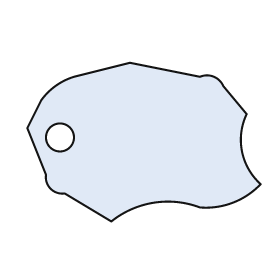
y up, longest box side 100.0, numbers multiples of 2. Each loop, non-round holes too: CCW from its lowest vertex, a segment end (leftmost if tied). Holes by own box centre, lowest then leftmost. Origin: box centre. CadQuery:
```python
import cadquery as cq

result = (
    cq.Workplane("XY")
    .moveTo(-14.0, -34.0)
    .threePointArc((4.0, -26.0), (24.0, -28.0))
    .threePointArc((38.0, -26.0), (50.0, -18.0))
    .threePointArc((42.0, -4.0), (44.0, 12.0))
    .lineTo(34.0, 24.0)
    .threePointArc((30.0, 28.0), (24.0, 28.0))
    .lineTo(-6.0, 34.0)
    .lineTo(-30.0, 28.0)
    .threePointArc((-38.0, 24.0), (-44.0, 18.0))
    .lineTo(-50.0, 6.0)
    .lineTo(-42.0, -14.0)
    .threePointArc((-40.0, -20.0), (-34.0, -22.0))
    .close()
    .moveTo(-36.0, 2.0)
    .circle(6.0)
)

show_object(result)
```